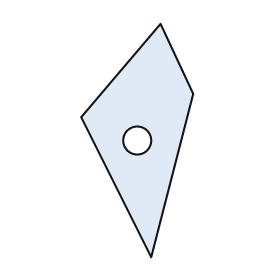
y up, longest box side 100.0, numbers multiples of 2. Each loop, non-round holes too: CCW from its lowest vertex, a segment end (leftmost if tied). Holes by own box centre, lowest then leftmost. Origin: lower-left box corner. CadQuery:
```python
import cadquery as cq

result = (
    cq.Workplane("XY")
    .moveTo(30.0, 0.0)
    .lineTo(48.0, 70.0)
    .lineTo(34.0, 100.0)
    .lineTo(0.0, 60.0)
    .close()
    .moveTo(24.0, 50.0)
    .circle(6.0)
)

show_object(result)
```